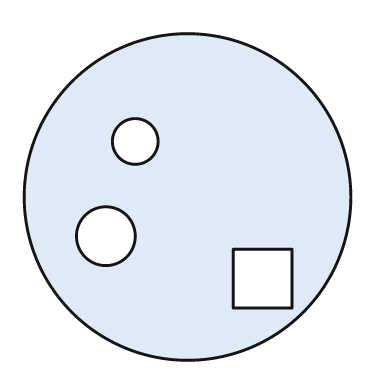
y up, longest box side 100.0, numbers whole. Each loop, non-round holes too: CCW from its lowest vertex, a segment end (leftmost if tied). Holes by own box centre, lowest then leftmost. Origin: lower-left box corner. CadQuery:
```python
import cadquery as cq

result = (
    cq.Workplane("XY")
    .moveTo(50.0, 50.0)
    .circle(50.0)
    .moveTo(64.0, 16.0)
    .lineTo(82.0, 16.0)
    .lineTo(82.0, 34.0)
    .lineTo(64.0, 34.0)
    .close()
    .moveTo(25.0, 38.0)
    .circle(9.0)
    .moveTo(34.0, 67.0)
    .circle(7.0)
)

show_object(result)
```